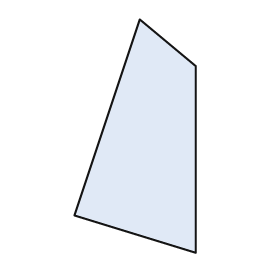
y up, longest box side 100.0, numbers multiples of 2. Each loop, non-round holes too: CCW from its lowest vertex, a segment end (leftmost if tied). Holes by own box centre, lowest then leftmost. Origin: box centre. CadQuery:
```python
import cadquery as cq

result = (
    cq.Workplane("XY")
    .moveTo(26.0, -50.0)
    .lineTo(26.0, 30.0)
    .lineTo(2.0, 50.0)
    .lineTo(-26.0, -34.0)
    .close()
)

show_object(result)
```